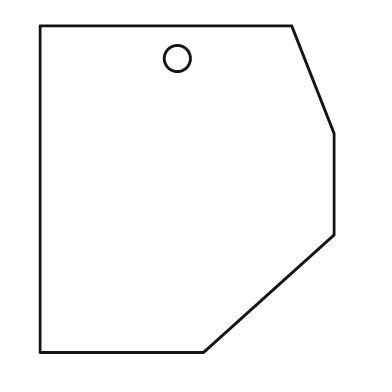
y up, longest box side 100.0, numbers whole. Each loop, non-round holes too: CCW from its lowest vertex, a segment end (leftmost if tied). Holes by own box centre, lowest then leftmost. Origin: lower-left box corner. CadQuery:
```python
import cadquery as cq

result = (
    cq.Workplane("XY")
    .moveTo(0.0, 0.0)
    .lineTo(50.0, 0.0)
    .lineTo(90.0, 36.0)
    .lineTo(90.0, 67.0)
    .lineTo(77.0, 100.0)
    .lineTo(0.0, 100.0)
    .close()
    .moveTo(42.0, 90.0)
    .circle(4.0)
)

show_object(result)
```